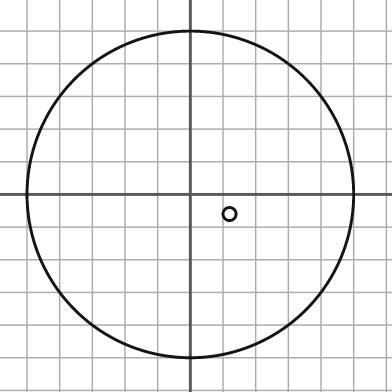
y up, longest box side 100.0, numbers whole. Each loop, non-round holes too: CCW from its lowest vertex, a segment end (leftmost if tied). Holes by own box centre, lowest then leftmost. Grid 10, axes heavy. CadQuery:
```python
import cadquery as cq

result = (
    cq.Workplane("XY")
    .moveTo(0.0, 0.0)
    .circle(50.0)
    .moveTo(12.0, -6.0)
    .circle(2.0)
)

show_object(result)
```